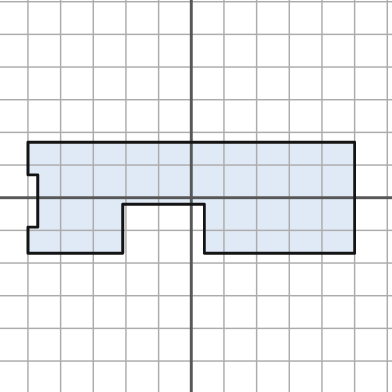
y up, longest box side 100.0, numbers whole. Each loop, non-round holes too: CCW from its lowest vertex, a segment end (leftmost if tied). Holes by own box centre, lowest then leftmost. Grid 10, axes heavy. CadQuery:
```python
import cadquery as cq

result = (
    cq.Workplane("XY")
    .moveTo(-50.0, -17.0)
    .lineTo(-21.0, -17.0)
    .lineTo(-21.0, -2.0)
    .lineTo(4.0, -2.0)
    .lineTo(4.0, -17.0)
    .lineTo(50.0, -17.0)
    .lineTo(50.0, 17.0)
    .lineTo(-50.0, 17.0)
    .lineTo(-50.0, 7.0)
    .lineTo(-47.0, 7.0)
    .lineTo(-47.0, -9.0)
    .lineTo(-50.0, -9.0)
    .close()
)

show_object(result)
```